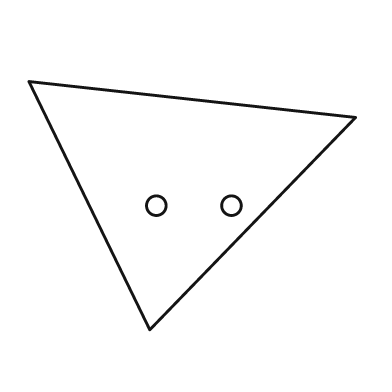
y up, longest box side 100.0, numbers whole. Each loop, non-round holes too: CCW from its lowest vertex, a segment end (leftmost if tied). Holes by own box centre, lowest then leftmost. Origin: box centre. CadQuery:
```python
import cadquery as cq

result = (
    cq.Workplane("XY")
    .moveTo(-13.0, -38.0)
    .lineTo(50.0, 27.0)
    .lineTo(-50.0, 38.0)
    .close()
    .moveTo(-11.0, 0.0)
    .circle(3.0)
    .moveTo(12.0, 0.0)
    .circle(3.0)
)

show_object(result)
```